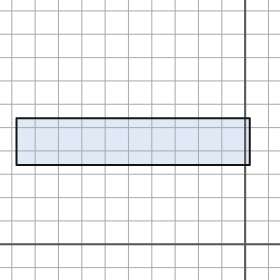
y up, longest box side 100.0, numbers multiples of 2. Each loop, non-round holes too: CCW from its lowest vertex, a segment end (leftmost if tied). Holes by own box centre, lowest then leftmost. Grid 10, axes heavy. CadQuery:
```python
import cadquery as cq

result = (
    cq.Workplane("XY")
    .moveTo(-98.0, 34.0)
    .lineTo(2.0, 34.0)
    .lineTo(2.0, 54.0)
    .lineTo(-98.0, 54.0)
    .close()
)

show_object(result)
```